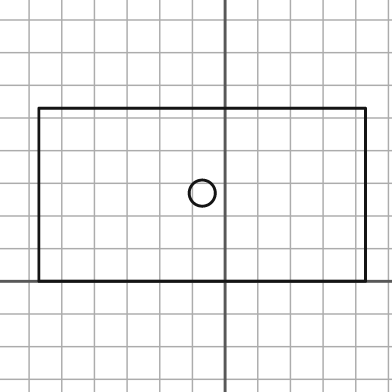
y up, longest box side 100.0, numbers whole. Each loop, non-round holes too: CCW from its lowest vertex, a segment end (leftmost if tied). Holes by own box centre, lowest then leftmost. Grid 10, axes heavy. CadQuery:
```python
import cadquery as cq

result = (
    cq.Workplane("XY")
    .moveTo(-57.0, 0.0)
    .lineTo(43.0, 0.0)
    .lineTo(43.0, 53.0)
    .lineTo(-57.0, 53.0)
    .close()
    .moveTo(-7.0, 27.0)
    .circle(4.0)
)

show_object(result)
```